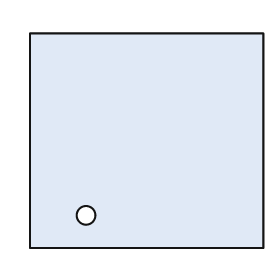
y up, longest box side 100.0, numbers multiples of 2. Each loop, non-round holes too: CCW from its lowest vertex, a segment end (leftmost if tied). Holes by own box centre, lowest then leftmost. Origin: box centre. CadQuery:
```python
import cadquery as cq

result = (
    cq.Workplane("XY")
    .moveTo(-50.0, -46.0)
    .lineTo(50.0, -46.0)
    .lineTo(50.0, 46.0)
    .lineTo(-50.0, 46.0)
    .close()
    .moveTo(-26.0, -32.0)
    .circle(4.0)
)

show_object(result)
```